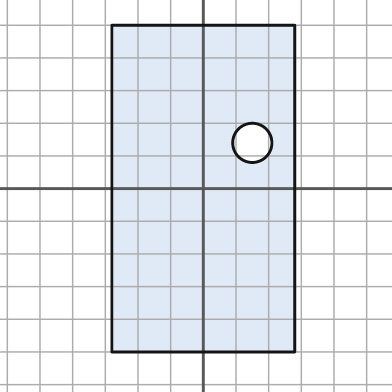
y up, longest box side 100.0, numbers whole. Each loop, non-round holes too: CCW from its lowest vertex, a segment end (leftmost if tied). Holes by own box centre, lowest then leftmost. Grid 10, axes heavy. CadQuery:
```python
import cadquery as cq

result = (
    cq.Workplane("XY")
    .moveTo(-28.0, -50.0)
    .lineTo(28.0, -50.0)
    .lineTo(28.0, 50.0)
    .lineTo(-28.0, 50.0)
    .close()
    .moveTo(15.0, 14.0)
    .circle(6.0)
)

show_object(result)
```